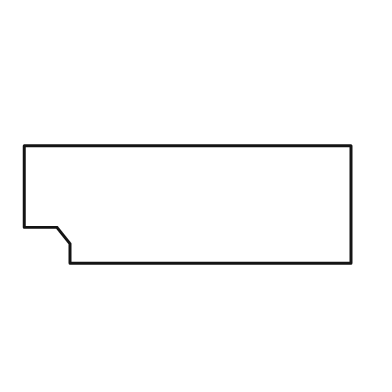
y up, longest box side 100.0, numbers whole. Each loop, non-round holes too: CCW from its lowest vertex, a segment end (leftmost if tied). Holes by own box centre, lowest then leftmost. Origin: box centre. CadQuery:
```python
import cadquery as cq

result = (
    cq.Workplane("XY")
    .moveTo(-36.0, -18.0)
    .lineTo(50.0, -18.0)
    .lineTo(50.0, 18.0)
    .lineTo(-50.0, 18.0)
    .lineTo(-50.0, -7.0)
    .lineTo(-40.0, -7.0)
    .lineTo(-36.0, -12.0)
    .close()
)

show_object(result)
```